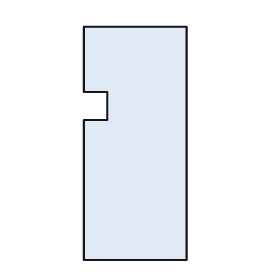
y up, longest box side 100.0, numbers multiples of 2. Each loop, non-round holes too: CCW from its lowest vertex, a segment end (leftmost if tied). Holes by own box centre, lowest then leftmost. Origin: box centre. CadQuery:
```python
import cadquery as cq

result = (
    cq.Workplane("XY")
    .moveTo(-22.0, -50.0)
    .lineTo(22.0, -50.0)
    .lineTo(22.0, 50.0)
    .lineTo(-22.0, 50.0)
    .lineTo(-22.0, 22.0)
    .lineTo(-12.0, 22.0)
    .lineTo(-12.0, 10.0)
    .lineTo(-22.0, 10.0)
    .close()
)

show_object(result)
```